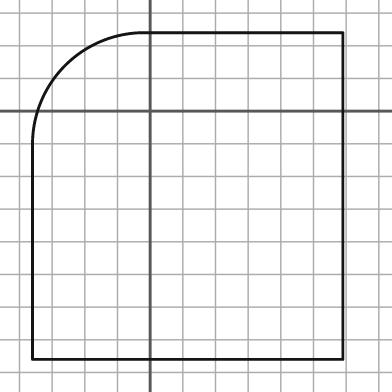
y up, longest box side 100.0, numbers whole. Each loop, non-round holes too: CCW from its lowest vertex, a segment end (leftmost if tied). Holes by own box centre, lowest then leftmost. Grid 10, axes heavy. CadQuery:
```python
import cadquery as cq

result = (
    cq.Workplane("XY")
    .moveTo(-36.0, -76.0)
    .lineTo(59.0, -76.0)
    .lineTo(59.0, 24.0)
    .lineTo(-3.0, 24.0)
    .threePointArc((-26.0, 14.0), (-36.0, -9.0))
    .close()
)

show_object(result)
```